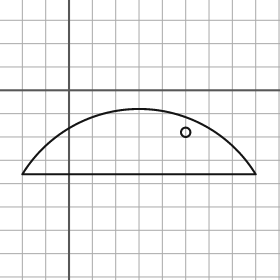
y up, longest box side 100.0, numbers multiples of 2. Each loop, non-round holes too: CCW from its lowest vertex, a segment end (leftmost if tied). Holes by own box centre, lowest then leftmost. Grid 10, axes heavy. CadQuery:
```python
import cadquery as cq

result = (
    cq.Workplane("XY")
    .moveTo(-20.0, -36.0)
    .lineTo(80.0, -36.0)
    .threePointArc((30.0, -8.0), (-20.0, -36.0))
    .close()
    .moveTo(50.0, -18.0)
    .circle(2.0)
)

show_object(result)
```